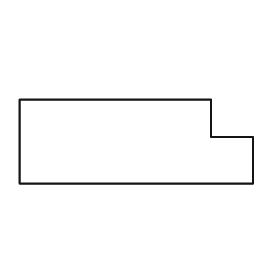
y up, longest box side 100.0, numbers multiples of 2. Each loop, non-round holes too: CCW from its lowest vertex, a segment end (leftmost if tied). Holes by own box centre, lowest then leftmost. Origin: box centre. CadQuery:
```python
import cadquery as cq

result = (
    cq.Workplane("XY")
    .moveTo(-50.0, -18.0)
    .lineTo(50.0, -18.0)
    .lineTo(50.0, 2.0)
    .lineTo(32.0, 2.0)
    .lineTo(32.0, 18.0)
    .lineTo(-50.0, 18.0)
    .close()
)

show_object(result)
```